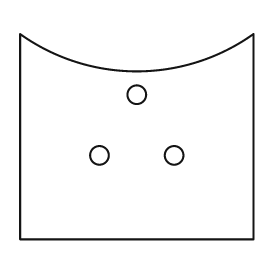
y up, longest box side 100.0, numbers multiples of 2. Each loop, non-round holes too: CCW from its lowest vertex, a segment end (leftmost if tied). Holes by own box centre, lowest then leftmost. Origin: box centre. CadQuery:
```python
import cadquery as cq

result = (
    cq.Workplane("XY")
    .moveTo(-50.0, -44.0)
    .lineTo(50.0, -44.0)
    .lineTo(50.0, 44.0)
    .threePointArc((0.0, 28.0), (-50.0, 44.0))
    .close()
    .moveTo(-16.0, -8.0)
    .circle(4.0)
    .moveTo(16.0, -8.0)
    .circle(4.0)
    .moveTo(0.0, 18.0)
    .circle(4.0)
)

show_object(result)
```